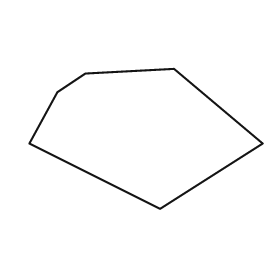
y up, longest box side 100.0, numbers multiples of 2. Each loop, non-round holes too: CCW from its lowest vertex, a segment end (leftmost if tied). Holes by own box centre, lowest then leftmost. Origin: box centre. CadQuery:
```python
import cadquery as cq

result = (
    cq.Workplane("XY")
    .moveTo(6.0, -30.0)
    .lineTo(50.0, -2.0)
    .lineTo(12.0, 30.0)
    .lineTo(-26.0, 28.0)
    .lineTo(-38.0, 20.0)
    .lineTo(-50.0, -2.0)
    .close()
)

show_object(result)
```